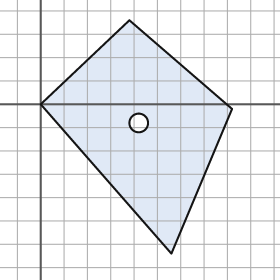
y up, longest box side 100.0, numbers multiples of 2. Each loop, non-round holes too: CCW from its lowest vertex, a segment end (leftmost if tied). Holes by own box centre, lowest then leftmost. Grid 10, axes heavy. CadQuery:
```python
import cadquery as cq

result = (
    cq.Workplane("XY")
    .moveTo(56.0, -64.0)
    .lineTo(82.0, -2.0)
    .lineTo(38.0, 36.0)
    .lineTo(0.0, 0.0)
    .close()
    .moveTo(42.0, -8.0)
    .circle(4.0)
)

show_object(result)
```